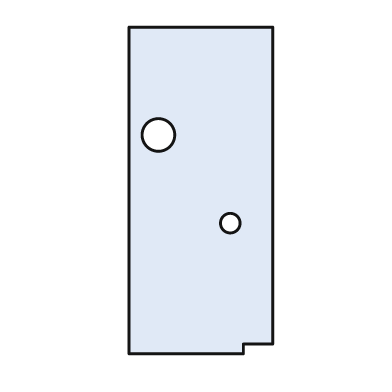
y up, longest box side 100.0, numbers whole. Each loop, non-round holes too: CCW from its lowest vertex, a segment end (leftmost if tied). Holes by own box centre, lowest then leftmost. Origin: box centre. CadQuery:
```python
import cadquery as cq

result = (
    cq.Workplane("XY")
    .moveTo(-22.0, -50.0)
    .lineTo(13.0, -50.0)
    .lineTo(13.0, -47.0)
    .lineTo(22.0, -47.0)
    .lineTo(22.0, 50.0)
    .lineTo(-22.0, 50.0)
    .close()
    .moveTo(9.0, -10.0)
    .circle(3.0)
    .moveTo(-13.0, 17.0)
    .circle(5.0)
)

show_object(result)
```